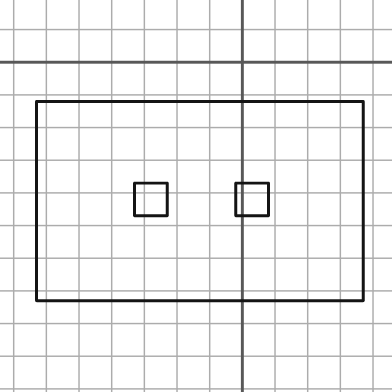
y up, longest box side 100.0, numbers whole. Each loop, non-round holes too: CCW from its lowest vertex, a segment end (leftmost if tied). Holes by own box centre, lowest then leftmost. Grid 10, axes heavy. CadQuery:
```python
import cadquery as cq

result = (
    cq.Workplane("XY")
    .moveTo(-63.0, -73.0)
    .lineTo(37.0, -73.0)
    .lineTo(37.0, -12.0)
    .lineTo(-63.0, -12.0)
    .close()
    .moveTo(-33.0, -47.0)
    .lineTo(-23.0, -47.0)
    .lineTo(-23.0, -37.0)
    .lineTo(-33.0, -37.0)
    .close()
    .moveTo(-2.0, -47.0)
    .lineTo(8.0, -47.0)
    .lineTo(8.0, -37.0)
    .lineTo(-2.0, -37.0)
    .close()
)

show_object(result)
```